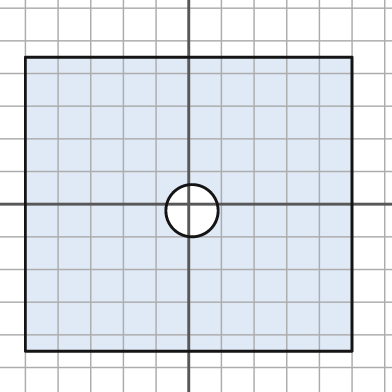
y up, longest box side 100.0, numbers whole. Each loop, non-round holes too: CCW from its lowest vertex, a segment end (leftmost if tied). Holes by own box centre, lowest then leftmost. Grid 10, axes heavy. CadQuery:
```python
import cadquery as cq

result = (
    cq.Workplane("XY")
    .moveTo(-50.0, -45.0)
    .lineTo(50.0, -45.0)
    .lineTo(50.0, 45.0)
    .lineTo(-50.0, 45.0)
    .close()
    .moveTo(1.0, -2.0)
    .circle(8.0)
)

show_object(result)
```